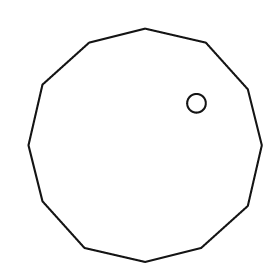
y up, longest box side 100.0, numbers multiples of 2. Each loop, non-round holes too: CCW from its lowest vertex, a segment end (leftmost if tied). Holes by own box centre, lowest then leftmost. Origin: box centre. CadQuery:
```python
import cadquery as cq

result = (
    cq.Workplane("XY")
    .moveTo(0.0, -50.0)
    .lineTo(24.0, -44.0)
    .lineTo(44.0, -26.0)
    .lineTo(50.0, 0.0)
    .lineTo(44.0, 24.0)
    .lineTo(26.0, 44.0)
    .lineTo(0.0, 50.0)
    .lineTo(-24.0, 44.0)
    .lineTo(-44.0, 26.0)
    .lineTo(-50.0, 0.0)
    .lineTo(-44.0, -24.0)
    .lineTo(-26.0, -44.0)
    .close()
    .moveTo(22.0, 18.0)
    .circle(4.0)
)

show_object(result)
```